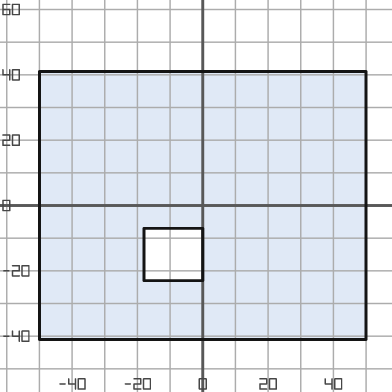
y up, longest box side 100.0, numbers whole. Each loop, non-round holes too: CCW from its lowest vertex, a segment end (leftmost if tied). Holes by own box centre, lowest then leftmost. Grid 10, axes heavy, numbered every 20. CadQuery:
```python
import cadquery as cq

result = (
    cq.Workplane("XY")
    .moveTo(-50.0, -41.0)
    .lineTo(50.0, -41.0)
    .lineTo(50.0, 41.0)
    .lineTo(-50.0, 41.0)
    .close()
    .moveTo(-18.0, -23.0)
    .lineTo(0.0, -23.0)
    .lineTo(0.0, -7.0)
    .lineTo(-18.0, -7.0)
    .close()
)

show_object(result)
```